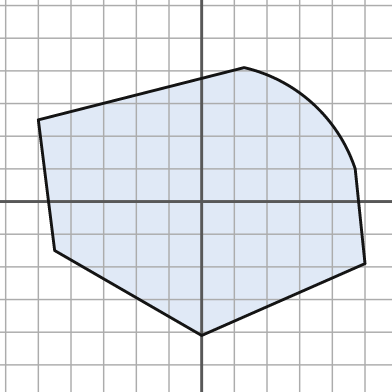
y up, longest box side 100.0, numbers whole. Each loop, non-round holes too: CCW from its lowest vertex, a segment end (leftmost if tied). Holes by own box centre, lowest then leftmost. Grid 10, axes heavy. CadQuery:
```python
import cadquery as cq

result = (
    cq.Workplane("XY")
    .moveTo(0.0, -41.0)
    .lineTo(50.0, -19.0)
    .lineTo(47.0, 10.0)
    .threePointArc((34.0, 30.0), (13.0, 41.0))
    .lineTo(-50.0, 25.0)
    .lineTo(-45.0, -15.0)
    .close()
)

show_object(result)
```